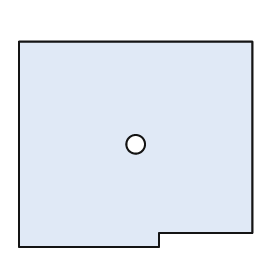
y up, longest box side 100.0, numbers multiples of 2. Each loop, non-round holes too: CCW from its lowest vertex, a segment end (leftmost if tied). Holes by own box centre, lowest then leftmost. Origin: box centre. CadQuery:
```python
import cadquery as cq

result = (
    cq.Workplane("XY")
    .moveTo(-50.0, -44.0)
    .lineTo(10.0, -44.0)
    .lineTo(10.0, -38.0)
    .lineTo(50.0, -38.0)
    .lineTo(50.0, 44.0)
    .lineTo(-50.0, 44.0)
    .close()
    .moveTo(0.0, 0.0)
    .circle(4.0)
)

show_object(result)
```